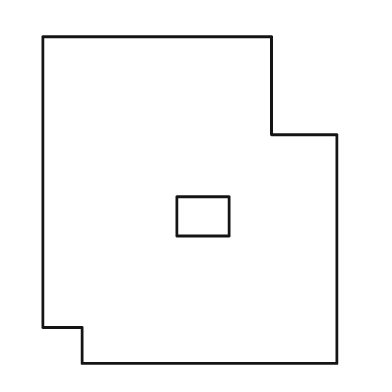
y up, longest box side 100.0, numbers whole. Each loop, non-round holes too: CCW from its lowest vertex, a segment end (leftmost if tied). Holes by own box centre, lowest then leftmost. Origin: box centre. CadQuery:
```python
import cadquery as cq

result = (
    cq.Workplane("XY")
    .moveTo(-33.0, -50.0)
    .lineTo(45.0, -50.0)
    .lineTo(45.0, 20.0)
    .lineTo(25.0, 20.0)
    .lineTo(25.0, 50.0)
    .lineTo(-45.0, 50.0)
    .lineTo(-45.0, -39.0)
    .lineTo(-33.0, -39.0)
    .close()
    .moveTo(-4.0, -11.0)
    .lineTo(12.0, -11.0)
    .lineTo(12.0, 1.0)
    .lineTo(-4.0, 1.0)
    .close()
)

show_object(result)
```